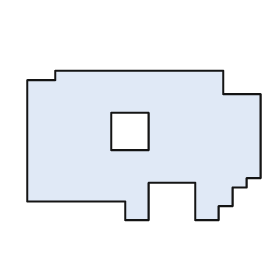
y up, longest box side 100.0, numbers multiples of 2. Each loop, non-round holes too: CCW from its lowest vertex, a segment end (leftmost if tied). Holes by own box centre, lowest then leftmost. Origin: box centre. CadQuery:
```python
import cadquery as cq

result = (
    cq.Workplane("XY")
    .moveTo(-8.0, -32.0)
    .lineTo(2.0, -32.0)
    .lineTo(2.0, -16.0)
    .lineTo(22.0, -16.0)
    .lineTo(22.0, -32.0)
    .lineTo(32.0, -32.0)
    .lineTo(32.0, -26.0)
    .lineTo(38.0, -26.0)
    .lineTo(38.0, -18.0)
    .lineTo(44.0, -18.0)
    .lineTo(44.0, -14.0)
    .lineTo(50.0, -14.0)
    .lineTo(50.0, 22.0)
    .lineTo(34.0, 22.0)
    .lineTo(34.0, 32.0)
    .lineTo(-38.0, 32.0)
    .lineTo(-38.0, 28.0)
    .lineTo(-50.0, 28.0)
    .lineTo(-50.0, -24.0)
    .lineTo(-8.0, -24.0)
    .close()
    .moveTo(-14.0, -2.0)
    .lineTo(2.0, -2.0)
    .lineTo(2.0, 14.0)
    .lineTo(-14.0, 14.0)
    .close()
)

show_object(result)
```